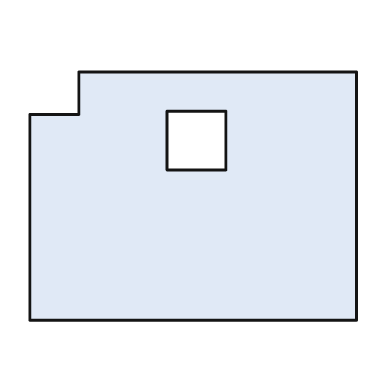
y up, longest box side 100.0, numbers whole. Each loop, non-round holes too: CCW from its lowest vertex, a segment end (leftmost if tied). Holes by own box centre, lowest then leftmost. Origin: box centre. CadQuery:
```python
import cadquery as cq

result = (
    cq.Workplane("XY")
    .moveTo(-50.0, -38.0)
    .lineTo(50.0, -38.0)
    .lineTo(50.0, 38.0)
    .lineTo(-35.0, 38.0)
    .lineTo(-35.0, 25.0)
    .lineTo(-50.0, 25.0)
    .close()
    .moveTo(-8.0, 8.0)
    .lineTo(10.0, 8.0)
    .lineTo(10.0, 26.0)
    .lineTo(-8.0, 26.0)
    .close()
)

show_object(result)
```